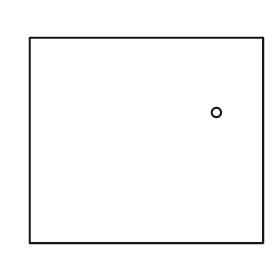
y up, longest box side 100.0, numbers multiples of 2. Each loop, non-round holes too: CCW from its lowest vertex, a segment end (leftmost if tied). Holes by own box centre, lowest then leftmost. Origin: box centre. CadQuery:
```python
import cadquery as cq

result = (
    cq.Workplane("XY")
    .moveTo(-50.0, -44.0)
    .lineTo(50.0, -44.0)
    .lineTo(50.0, 44.0)
    .lineTo(-50.0, 44.0)
    .close()
    .moveTo(30.0, 12.0)
    .circle(2.0)
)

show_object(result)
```